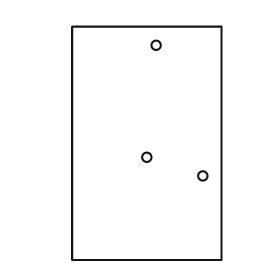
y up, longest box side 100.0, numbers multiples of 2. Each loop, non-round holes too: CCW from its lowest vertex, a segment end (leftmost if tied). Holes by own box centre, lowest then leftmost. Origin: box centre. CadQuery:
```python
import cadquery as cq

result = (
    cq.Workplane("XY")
    .moveTo(-32.0, -50.0)
    .lineTo(32.0, -50.0)
    .lineTo(32.0, 50.0)
    .lineTo(-32.0, 50.0)
    .close()
    .moveTo(24.0, -14.0)
    .circle(2.0)
    .moveTo(0.0, -6.0)
    .circle(2.0)
    .moveTo(4.0, 42.0)
    .circle(2.0)
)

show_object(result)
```